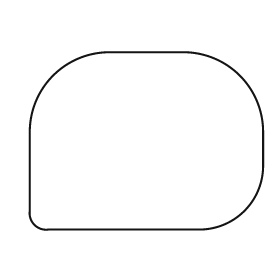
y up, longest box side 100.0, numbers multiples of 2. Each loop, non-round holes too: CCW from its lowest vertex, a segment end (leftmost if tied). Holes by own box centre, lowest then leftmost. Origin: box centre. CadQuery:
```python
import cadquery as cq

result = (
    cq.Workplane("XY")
    .moveTo(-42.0, -38.0)
    .lineTo(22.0, -38.0)
    .threePointArc((42.0, -30.0), (50.0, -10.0))
    .lineTo(50.0, 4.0)
    .threePointArc((40.0, 28.0), (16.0, 38.0))
    .lineTo(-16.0, 38.0)
    .threePointArc((-40.0, 28.0), (-50.0, 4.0))
    .lineTo(-50.0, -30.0)
    .threePointArc((-48.0, -36.0), (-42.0, -38.0))
    .close()
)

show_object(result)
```